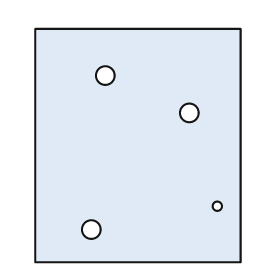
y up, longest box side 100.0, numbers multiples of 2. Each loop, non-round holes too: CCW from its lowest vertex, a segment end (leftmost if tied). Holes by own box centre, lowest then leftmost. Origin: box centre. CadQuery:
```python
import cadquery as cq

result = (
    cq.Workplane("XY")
    .moveTo(-44.0, -50.0)
    .lineTo(44.0, -50.0)
    .lineTo(44.0, 50.0)
    .lineTo(-44.0, 50.0)
    .close()
    .moveTo(-20.0, -36.0)
    .circle(4.0)
    .moveTo(34.0, -26.0)
    .circle(2.0)
    .moveTo(22.0, 14.0)
    .circle(4.0)
    .moveTo(-14.0, 30.0)
    .circle(4.0)
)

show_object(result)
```